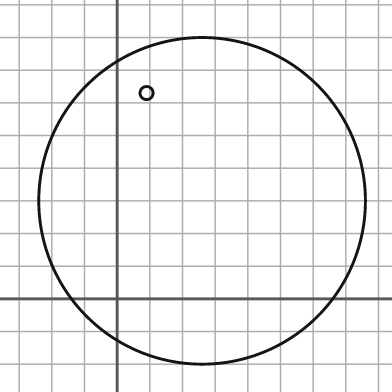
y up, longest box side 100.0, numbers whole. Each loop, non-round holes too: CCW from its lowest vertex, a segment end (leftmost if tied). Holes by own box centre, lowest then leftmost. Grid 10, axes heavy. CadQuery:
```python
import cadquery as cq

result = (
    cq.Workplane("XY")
    .moveTo(26.0, 30.0)
    .circle(50.0)
    .moveTo(9.0, 63.0)
    .circle(2.0)
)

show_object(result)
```